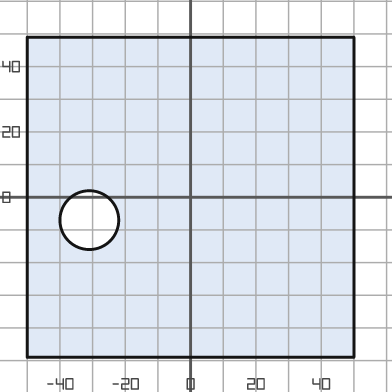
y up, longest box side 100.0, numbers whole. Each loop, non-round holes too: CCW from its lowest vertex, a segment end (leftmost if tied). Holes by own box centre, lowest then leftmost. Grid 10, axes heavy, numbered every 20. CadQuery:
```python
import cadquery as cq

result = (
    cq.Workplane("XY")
    .moveTo(-50.0, -49.0)
    .lineTo(50.0, -49.0)
    .lineTo(50.0, 49.0)
    .lineTo(-50.0, 49.0)
    .close()
    .moveTo(-31.0, -7.0)
    .circle(9.0)
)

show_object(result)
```